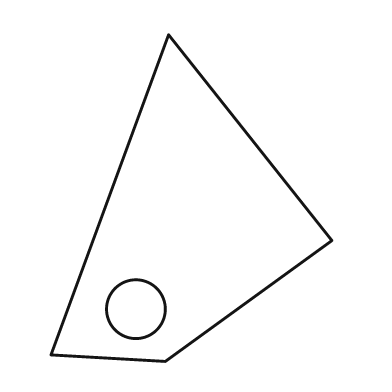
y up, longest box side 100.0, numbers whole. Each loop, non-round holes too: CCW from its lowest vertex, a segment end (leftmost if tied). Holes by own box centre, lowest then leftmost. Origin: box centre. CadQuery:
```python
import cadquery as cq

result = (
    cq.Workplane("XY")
    .moveTo(-8.0, -50.0)
    .lineTo(43.0, -13.0)
    .lineTo(-7.0, 50.0)
    .lineTo(-43.0, -48.0)
    .close()
    .moveTo(-17.0, -34.0)
    .circle(9.0)
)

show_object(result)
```